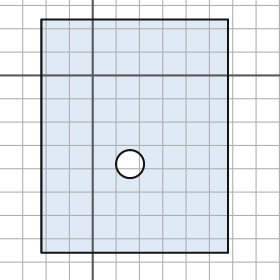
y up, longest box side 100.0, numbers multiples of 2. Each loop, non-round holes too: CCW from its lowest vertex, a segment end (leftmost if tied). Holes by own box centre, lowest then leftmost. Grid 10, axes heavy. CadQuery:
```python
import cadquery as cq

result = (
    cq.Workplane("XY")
    .moveTo(-22.0, -76.0)
    .lineTo(58.0, -76.0)
    .lineTo(58.0, 24.0)
    .lineTo(-22.0, 24.0)
    .close()
    .moveTo(16.0, -38.0)
    .circle(6.0)
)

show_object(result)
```